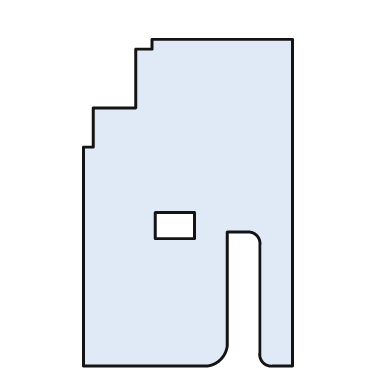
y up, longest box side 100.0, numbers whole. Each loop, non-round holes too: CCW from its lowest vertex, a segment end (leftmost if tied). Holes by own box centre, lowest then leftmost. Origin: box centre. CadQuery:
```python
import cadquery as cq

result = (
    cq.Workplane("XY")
    .moveTo(-32.0, -50.0)
    .lineTo(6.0, -50.0)
    .threePointArc((10.0, -48.0), (12.0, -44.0))
    .lineTo(12.0, -9.0)
    .lineTo(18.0, -9.0)
    .threePointArc((21.0, -10.0), (22.0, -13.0))
    .lineTo(22.0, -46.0)
    .threePointArc((23.0, -49.0), (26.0, -50.0))
    .lineTo(32.0, -50.0)
    .lineTo(32.0, 50.0)
    .lineTo(-11.0, 50.0)
    .lineTo(-11.0, 47.0)
    .lineTo(-16.0, 47.0)
    .lineTo(-16.0, 29.0)
    .lineTo(-29.0, 29.0)
    .lineTo(-29.0, 17.0)
    .lineTo(-32.0, 17.0)
    .close()
    .moveTo(-10.0, -11.0)
    .lineTo(2.0, -11.0)
    .lineTo(2.0, -3.0)
    .lineTo(-10.0, -3.0)
    .close()
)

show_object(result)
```